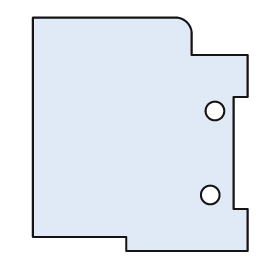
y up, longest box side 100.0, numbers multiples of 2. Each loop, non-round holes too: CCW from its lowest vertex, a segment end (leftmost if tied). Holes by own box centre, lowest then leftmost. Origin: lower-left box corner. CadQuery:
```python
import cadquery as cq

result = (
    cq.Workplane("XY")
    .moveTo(40.0, 0.0)
    .lineTo(92.0, 0.0)
    .lineTo(92.0, 18.0)
    .lineTo(86.0, 18.0)
    .lineTo(86.0, 66.0)
    .lineTo(92.0, 66.0)
    .lineTo(92.0, 84.0)
    .lineTo(68.0, 84.0)
    .lineTo(68.0, 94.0)
    .threePointArc((66.0, 98.0), (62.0, 100.0))
    .lineTo(0.0, 100.0)
    .lineTo(0.0, 6.0)
    .lineTo(40.0, 6.0)
    .close()
    .moveTo(76.0, 24.0)
    .circle(4.0)
    .moveTo(78.0, 60.0)
    .circle(4.0)
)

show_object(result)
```